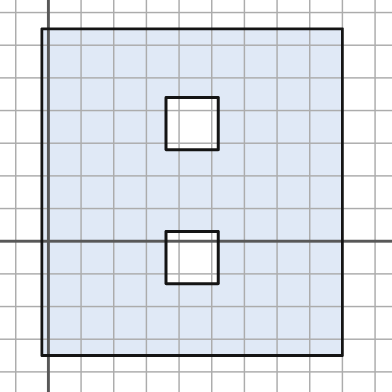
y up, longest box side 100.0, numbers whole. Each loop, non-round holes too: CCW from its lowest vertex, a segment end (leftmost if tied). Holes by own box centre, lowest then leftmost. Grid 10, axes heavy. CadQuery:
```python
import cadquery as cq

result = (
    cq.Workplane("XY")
    .moveTo(-2.0, -35.0)
    .lineTo(90.0, -35.0)
    .lineTo(90.0, 65.0)
    .lineTo(-2.0, 65.0)
    .close()
    .moveTo(36.0, -13.0)
    .lineTo(52.0, -13.0)
    .lineTo(52.0, 3.0)
    .lineTo(36.0, 3.0)
    .close()
    .moveTo(36.0, 28.0)
    .lineTo(52.0, 28.0)
    .lineTo(52.0, 44.0)
    .lineTo(36.0, 44.0)
    .close()
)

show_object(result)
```